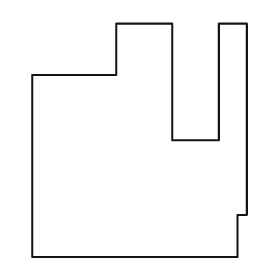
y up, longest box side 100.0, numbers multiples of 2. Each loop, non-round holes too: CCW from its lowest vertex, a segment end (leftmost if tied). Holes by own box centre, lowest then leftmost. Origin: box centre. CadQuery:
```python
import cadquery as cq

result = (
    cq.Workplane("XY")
    .moveTo(-46.0, -50.0)
    .lineTo(42.0, -50.0)
    .lineTo(42.0, -32.0)
    .lineTo(46.0, -32.0)
    .lineTo(46.0, 50.0)
    .lineTo(34.0, 50.0)
    .lineTo(34.0, 0.0)
    .lineTo(14.0, 0.0)
    .lineTo(14.0, 50.0)
    .lineTo(-10.0, 50.0)
    .lineTo(-10.0, 28.0)
    .lineTo(-46.0, 28.0)
    .close()
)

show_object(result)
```